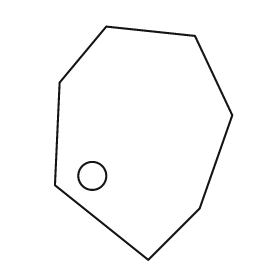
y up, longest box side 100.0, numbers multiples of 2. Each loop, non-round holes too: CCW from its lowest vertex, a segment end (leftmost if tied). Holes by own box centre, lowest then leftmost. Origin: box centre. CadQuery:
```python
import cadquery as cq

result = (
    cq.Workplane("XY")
    .moveTo(2.0, -50.0)
    .lineTo(24.0, -28.0)
    .lineTo(38.0, 12.0)
    .lineTo(22.0, 46.0)
    .lineTo(-16.0, 50.0)
    .lineTo(-36.0, 26.0)
    .lineTo(-38.0, -18.0)
    .close()
    .moveTo(-22.0, -14.0)
    .circle(6.0)
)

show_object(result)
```